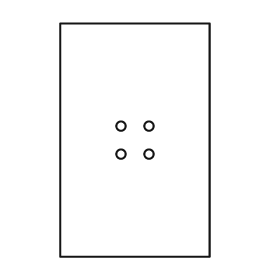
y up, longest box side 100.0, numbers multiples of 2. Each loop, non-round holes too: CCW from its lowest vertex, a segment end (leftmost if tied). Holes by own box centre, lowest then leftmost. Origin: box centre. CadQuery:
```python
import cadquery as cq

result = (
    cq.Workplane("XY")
    .moveTo(-32.0, -50.0)
    .lineTo(32.0, -50.0)
    .lineTo(32.0, 50.0)
    .lineTo(-32.0, 50.0)
    .close()
    .moveTo(-6.0, -6.0)
    .circle(2.0)
    .moveTo(6.0, -6.0)
    .circle(2.0)
    .moveTo(-6.0, 6.0)
    .circle(2.0)
    .moveTo(6.0, 6.0)
    .circle(2.0)
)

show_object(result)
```